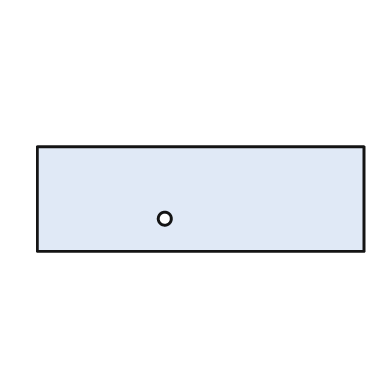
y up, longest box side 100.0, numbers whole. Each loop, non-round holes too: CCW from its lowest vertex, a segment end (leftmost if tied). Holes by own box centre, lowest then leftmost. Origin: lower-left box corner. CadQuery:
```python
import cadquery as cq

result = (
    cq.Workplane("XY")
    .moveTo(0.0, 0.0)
    .lineTo(100.0, 0.0)
    .lineTo(100.0, 32.0)
    .lineTo(0.0, 32.0)
    .close()
    .moveTo(39.0, 10.0)
    .circle(2.0)
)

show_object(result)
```